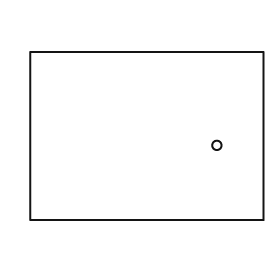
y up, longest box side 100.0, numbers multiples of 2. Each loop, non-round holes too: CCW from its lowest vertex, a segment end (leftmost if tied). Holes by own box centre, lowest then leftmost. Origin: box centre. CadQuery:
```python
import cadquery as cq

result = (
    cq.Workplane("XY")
    .moveTo(-50.0, -36.0)
    .lineTo(50.0, -36.0)
    .lineTo(50.0, 36.0)
    .lineTo(-50.0, 36.0)
    .close()
    .moveTo(30.0, -4.0)
    .circle(2.0)
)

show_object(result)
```